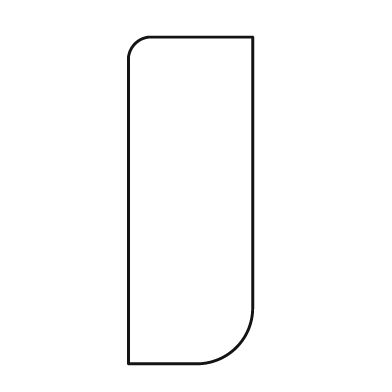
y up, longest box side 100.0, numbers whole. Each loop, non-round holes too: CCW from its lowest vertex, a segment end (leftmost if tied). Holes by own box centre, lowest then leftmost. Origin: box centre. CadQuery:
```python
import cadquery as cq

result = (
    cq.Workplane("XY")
    .moveTo(-19.0, -50.0)
    .lineTo(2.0, -50.0)
    .threePointArc((14.0, -45.0), (19.0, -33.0))
    .lineTo(19.0, 50.0)
    .lineTo(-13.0, 50.0)
    .threePointArc((-17.0, 48.0), (-19.0, 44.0))
    .close()
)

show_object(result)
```